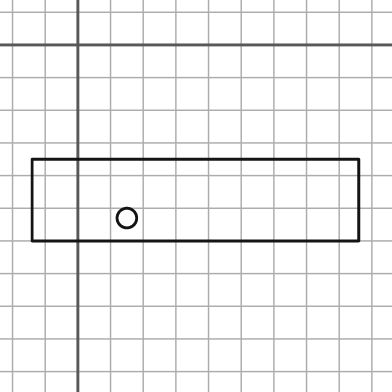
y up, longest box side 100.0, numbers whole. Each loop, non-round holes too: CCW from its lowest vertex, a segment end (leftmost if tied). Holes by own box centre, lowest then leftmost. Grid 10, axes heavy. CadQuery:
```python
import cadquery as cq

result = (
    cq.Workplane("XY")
    .moveTo(-14.0, -60.0)
    .lineTo(86.0, -60.0)
    .lineTo(86.0, -35.0)
    .lineTo(-14.0, -35.0)
    .close()
    .moveTo(15.0, -53.0)
    .circle(3.0)
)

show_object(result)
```